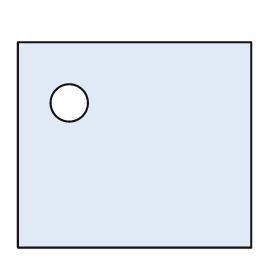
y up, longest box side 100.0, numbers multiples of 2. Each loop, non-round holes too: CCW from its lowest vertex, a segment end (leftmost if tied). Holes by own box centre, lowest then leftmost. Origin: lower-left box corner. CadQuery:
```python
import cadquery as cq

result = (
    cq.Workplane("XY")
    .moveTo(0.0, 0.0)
    .lineTo(100.0, 0.0)
    .lineTo(100.0, 88.0)
    .lineTo(0.0, 88.0)
    .close()
    .moveTo(22.0, 62.0)
    .circle(8.0)
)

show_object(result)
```